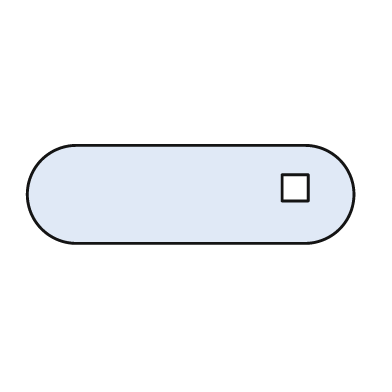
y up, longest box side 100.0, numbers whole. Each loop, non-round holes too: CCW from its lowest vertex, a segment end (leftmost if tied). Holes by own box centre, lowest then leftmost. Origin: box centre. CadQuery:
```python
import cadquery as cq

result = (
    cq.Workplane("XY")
    .moveTo(-35.0, -15.0)
    .lineTo(35.0, -15.0)
    .threePointArc((50.0, 0.0), (35.0, 15.0))
    .lineTo(-35.0, 15.0)
    .threePointArc((-50.0, 0.0), (-35.0, -15.0))
    .close()
    .moveTo(28.0, -2.0)
    .lineTo(36.0, -2.0)
    .lineTo(36.0, 6.0)
    .lineTo(28.0, 6.0)
    .close()
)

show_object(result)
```